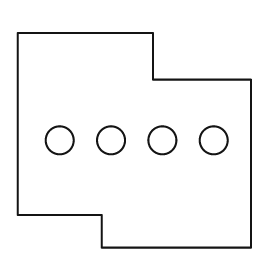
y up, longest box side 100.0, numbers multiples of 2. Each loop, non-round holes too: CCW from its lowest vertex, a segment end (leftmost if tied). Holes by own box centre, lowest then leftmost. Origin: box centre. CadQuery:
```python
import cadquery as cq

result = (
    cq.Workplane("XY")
    .moveTo(-14.0, -46.0)
    .lineTo(50.0, -46.0)
    .lineTo(50.0, 26.0)
    .lineTo(8.0, 26.0)
    .lineTo(8.0, 46.0)
    .lineTo(-50.0, 46.0)
    .lineTo(-50.0, -32.0)
    .lineTo(-14.0, -32.0)
    .close()
    .moveTo(-32.0, 0.0)
    .circle(6.0)
    .moveTo(-10.0, 0.0)
    .circle(6.0)
    .moveTo(12.0, 0.0)
    .circle(6.0)
    .moveTo(34.0, 0.0)
    .circle(6.0)
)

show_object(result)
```